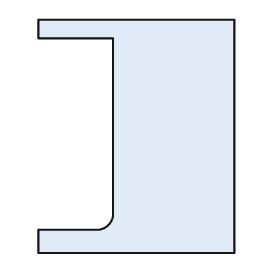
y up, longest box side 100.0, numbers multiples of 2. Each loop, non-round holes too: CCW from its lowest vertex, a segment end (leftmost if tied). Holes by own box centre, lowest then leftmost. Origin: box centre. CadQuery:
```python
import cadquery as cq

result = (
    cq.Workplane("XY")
    .moveTo(-42.0, -50.0)
    .lineTo(42.0, -50.0)
    .lineTo(42.0, 50.0)
    .lineTo(-42.0, 50.0)
    .lineTo(-42.0, 42.0)
    .lineTo(-10.0, 42.0)
    .lineTo(-10.0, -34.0)
    .threePointArc((-12.0, -38.0), (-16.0, -40.0))
    .lineTo(-42.0, -40.0)
    .close()
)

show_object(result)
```